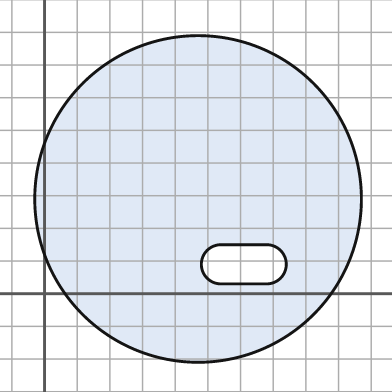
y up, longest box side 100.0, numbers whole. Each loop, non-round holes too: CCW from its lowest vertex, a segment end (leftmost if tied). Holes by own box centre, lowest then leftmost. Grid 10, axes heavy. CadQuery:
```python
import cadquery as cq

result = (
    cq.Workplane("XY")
    .moveTo(47.0, 29.0)
    .circle(50.0)
    .moveTo(54.0, 3.0)
    .lineTo(68.0, 3.0)
    .threePointArc((74.0, 9.0), (68.0, 15.0))
    .lineTo(54.0, 15.0)
    .threePointArc((48.0, 9.0), (54.0, 3.0))
    .close()
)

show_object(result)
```